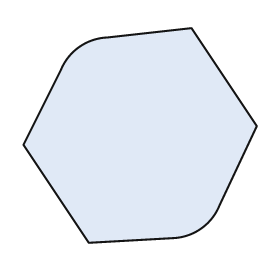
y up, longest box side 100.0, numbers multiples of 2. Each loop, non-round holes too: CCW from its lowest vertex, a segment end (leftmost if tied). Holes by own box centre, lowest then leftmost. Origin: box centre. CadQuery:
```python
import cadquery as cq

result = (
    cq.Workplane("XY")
    .moveTo(-22.0, -46.0)
    .lineTo(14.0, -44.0)
    .threePointArc((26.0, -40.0), (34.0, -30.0))
    .lineTo(50.0, 4.0)
    .lineTo(22.0, 46.0)
    .lineTo(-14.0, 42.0)
    .threePointArc((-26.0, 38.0), (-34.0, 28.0))
    .lineTo(-50.0, -4.0)
    .close()
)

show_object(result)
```